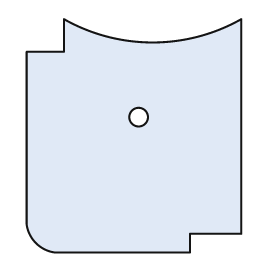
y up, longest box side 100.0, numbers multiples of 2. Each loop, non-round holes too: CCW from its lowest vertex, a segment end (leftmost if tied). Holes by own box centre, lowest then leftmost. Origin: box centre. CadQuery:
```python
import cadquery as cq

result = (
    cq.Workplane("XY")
    .moveTo(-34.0, -50.0)
    .lineTo(24.0, -50.0)
    .lineTo(24.0, -42.0)
    .lineTo(46.0, -42.0)
    .lineTo(46.0, 50.0)
    .threePointArc((8.0, 40.0), (-30.0, 50.0))
    .lineTo(-30.0, 36.0)
    .lineTo(-46.0, 36.0)
    .lineTo(-46.0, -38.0)
    .threePointArc((-42.0, -46.0), (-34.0, -50.0))
    .close()
    .moveTo(2.0, 8.0)
    .circle(4.0)
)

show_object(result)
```